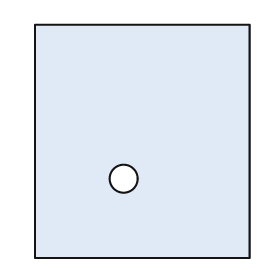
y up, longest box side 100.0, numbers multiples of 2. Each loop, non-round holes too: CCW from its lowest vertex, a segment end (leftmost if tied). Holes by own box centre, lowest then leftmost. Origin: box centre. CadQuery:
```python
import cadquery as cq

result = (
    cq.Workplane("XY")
    .moveTo(-46.0, -50.0)
    .lineTo(46.0, -50.0)
    .lineTo(46.0, 50.0)
    .lineTo(-46.0, 50.0)
    .close()
    .moveTo(-8.0, -16.0)
    .circle(6.0)
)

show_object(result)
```